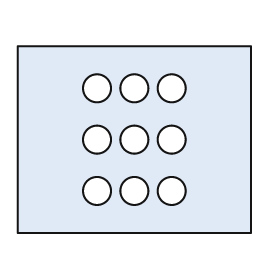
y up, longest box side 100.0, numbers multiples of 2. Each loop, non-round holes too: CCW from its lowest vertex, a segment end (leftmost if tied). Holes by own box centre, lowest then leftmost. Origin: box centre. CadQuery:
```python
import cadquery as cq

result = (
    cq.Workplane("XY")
    .moveTo(-50.0, -40.0)
    .lineTo(50.0, -40.0)
    .lineTo(50.0, 40.0)
    .lineTo(-50.0, 40.0)
    .close()
    .moveTo(-16.0, -22.0)
    .circle(6.0)
    .moveTo(0.0, -22.0)
    .circle(6.0)
    .moveTo(16.0, -22.0)
    .circle(6.0)
    .moveTo(-16.0, 0.0)
    .circle(6.0)
    .moveTo(0.0, 0.0)
    .circle(6.0)
    .moveTo(16.0, 0.0)
    .circle(6.0)
    .moveTo(-16.0, 22.0)
    .circle(6.0)
    .moveTo(0.0, 22.0)
    .circle(6.0)
    .moveTo(16.0, 22.0)
    .circle(6.0)
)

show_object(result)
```